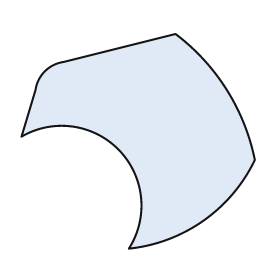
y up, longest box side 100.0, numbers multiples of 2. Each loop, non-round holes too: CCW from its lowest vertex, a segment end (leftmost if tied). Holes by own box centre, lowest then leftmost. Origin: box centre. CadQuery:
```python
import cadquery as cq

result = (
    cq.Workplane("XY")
    .moveTo(-4.0, -46.0)
    .threePointArc((28.0, -34.0), (50.0, -8.0))
    .threePointArc((38.0, 22.0), (16.0, 46.0))
    .lineTo(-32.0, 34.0)
    .threePointArc((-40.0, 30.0), (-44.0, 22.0))
    .lineTo(-50.0, 2.0)
    .threePointArc((-8.0, -4.0), (-4.0, -46.0))
    .close()
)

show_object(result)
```